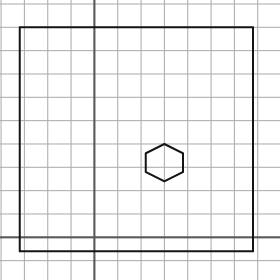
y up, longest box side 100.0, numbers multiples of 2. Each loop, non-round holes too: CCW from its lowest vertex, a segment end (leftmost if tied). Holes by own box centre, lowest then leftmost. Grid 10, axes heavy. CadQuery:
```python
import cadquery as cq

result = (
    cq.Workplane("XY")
    .moveTo(-32.0, -6.0)
    .lineTo(68.0, -6.0)
    .lineTo(68.0, 90.0)
    .lineTo(-32.0, 90.0)
    .close()
    .moveTo(30.0, 24.0)
    .lineTo(38.0, 28.0)
    .lineTo(38.0, 36.0)
    .lineTo(30.0, 40.0)
    .lineTo(22.0, 36.0)
    .lineTo(22.0, 28.0)
    .close()
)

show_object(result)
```